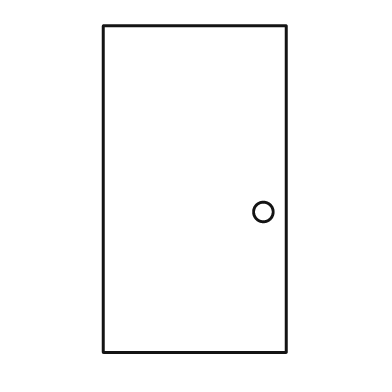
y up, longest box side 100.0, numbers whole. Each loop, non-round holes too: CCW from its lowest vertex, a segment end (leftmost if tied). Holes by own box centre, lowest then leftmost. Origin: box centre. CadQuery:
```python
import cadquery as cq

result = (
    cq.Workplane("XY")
    .moveTo(-28.0, -50.0)
    .lineTo(28.0, -50.0)
    .lineTo(28.0, 50.0)
    .lineTo(-28.0, 50.0)
    .close()
    .moveTo(21.0, -7.0)
    .circle(3.0)
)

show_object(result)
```